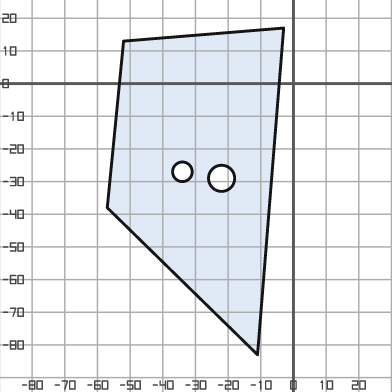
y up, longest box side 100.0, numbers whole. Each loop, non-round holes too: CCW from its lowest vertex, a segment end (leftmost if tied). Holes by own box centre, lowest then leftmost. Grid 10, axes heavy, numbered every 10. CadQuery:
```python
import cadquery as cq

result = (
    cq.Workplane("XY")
    .moveTo(-11.0, -83.0)
    .lineTo(-3.0, 17.0)
    .lineTo(-52.0, 13.0)
    .lineTo(-57.0, -38.0)
    .close()
    .moveTo(-22.0, -29.0)
    .circle(4.0)
    .moveTo(-34.0, -27.0)
    .circle(3.0)
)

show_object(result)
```